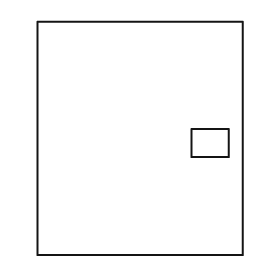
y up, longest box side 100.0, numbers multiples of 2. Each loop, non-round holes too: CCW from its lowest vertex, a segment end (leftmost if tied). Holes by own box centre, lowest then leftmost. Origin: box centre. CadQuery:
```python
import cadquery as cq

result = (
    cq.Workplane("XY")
    .moveTo(-44.0, -50.0)
    .lineTo(44.0, -50.0)
    .lineTo(44.0, 50.0)
    .lineTo(-44.0, 50.0)
    .close()
    .moveTo(22.0, -8.0)
    .lineTo(38.0, -8.0)
    .lineTo(38.0, 4.0)
    .lineTo(22.0, 4.0)
    .close()
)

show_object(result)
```